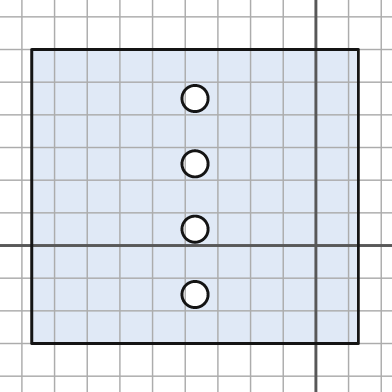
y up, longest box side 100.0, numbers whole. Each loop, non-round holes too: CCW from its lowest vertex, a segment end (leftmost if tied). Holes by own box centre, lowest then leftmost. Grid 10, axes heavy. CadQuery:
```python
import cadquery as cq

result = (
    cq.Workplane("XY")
    .moveTo(-87.0, -30.0)
    .lineTo(13.0, -30.0)
    .lineTo(13.0, 60.0)
    .lineTo(-87.0, 60.0)
    .close()
    .moveTo(-37.0, -15.0)
    .circle(4.0)
    .moveTo(-37.0, 5.0)
    .circle(4.0)
    .moveTo(-37.0, 25.0)
    .circle(4.0)
    .moveTo(-37.0, 45.0)
    .circle(4.0)
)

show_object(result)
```